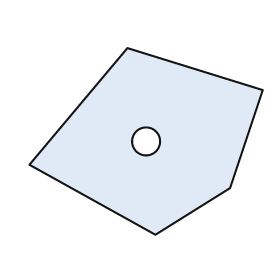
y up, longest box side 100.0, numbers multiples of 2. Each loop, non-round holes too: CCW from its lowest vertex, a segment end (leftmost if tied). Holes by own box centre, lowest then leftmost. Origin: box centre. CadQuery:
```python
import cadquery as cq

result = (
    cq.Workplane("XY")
    .moveTo(4.0, -40.0)
    .lineTo(36.0, -20.0)
    .lineTo(50.0, 22.0)
    .lineTo(-8.0, 40.0)
    .lineTo(-50.0, -10.0)
    .close()
    .moveTo(0.0, 0.0)
    .circle(6.0)
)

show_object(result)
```